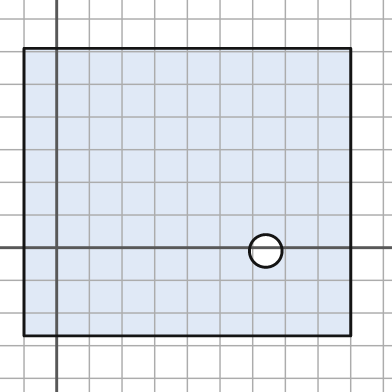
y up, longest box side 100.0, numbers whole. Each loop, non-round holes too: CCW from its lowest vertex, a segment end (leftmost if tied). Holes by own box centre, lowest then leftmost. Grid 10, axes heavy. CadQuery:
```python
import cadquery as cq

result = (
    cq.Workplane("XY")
    .moveTo(-10.0, -27.0)
    .lineTo(90.0, -27.0)
    .lineTo(90.0, 61.0)
    .lineTo(-10.0, 61.0)
    .close()
    .moveTo(64.0, -1.0)
    .circle(5.0)
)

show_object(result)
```